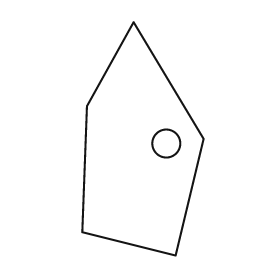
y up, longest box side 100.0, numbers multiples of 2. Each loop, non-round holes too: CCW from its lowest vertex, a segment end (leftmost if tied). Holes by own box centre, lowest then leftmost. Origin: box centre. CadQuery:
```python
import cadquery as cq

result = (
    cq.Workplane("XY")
    .moveTo(14.0, -50.0)
    .lineTo(26.0, 0.0)
    .lineTo(-4.0, 50.0)
    .lineTo(-24.0, 14.0)
    .lineTo(-26.0, -40.0)
    .close()
    .moveTo(10.0, -2.0)
    .circle(6.0)
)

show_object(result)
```